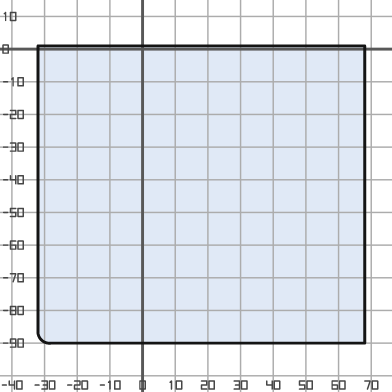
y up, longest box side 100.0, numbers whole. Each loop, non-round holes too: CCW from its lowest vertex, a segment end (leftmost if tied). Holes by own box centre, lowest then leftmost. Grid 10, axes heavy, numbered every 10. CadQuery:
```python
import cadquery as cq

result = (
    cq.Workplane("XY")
    .moveTo(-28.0, -90.0)
    .lineTo(68.0, -90.0)
    .lineTo(68.0, 1.0)
    .lineTo(-32.0, 1.0)
    .lineTo(-32.0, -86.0)
    .threePointArc((-31.0, -89.0), (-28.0, -90.0))
    .close()
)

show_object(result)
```